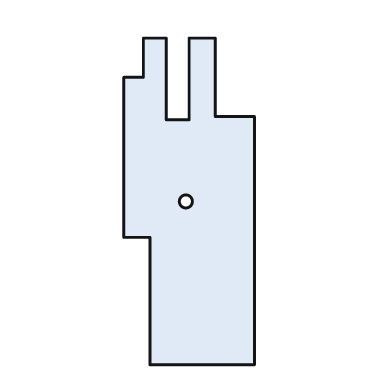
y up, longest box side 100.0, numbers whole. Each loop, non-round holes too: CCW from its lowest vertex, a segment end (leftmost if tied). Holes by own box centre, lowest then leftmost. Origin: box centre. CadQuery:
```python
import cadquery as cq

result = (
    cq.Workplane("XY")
    .moveTo(-12.0, -50.0)
    .lineTo(20.0, -50.0)
    .lineTo(20.0, 26.0)
    .lineTo(8.0, 26.0)
    .lineTo(8.0, 50.0)
    .lineTo(0.0, 50.0)
    .lineTo(0.0, 25.0)
    .lineTo(-7.0, 25.0)
    .lineTo(-7.0, 50.0)
    .lineTo(-14.0, 50.0)
    .lineTo(-14.0, 38.0)
    .lineTo(-20.0, 38.0)
    .lineTo(-20.0, -11.0)
    .lineTo(-12.0, -11.0)
    .close()
    .moveTo(-1.0, 0.0)
    .circle(2.0)
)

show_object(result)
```